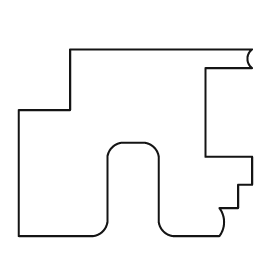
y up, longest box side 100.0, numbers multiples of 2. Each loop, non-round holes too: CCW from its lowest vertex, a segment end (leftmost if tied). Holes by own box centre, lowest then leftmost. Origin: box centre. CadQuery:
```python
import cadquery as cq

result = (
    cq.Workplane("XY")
    .moveTo(-50.0, -40.0)
    .lineTo(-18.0, -40.0)
    .threePointArc((-14.0, -38.0), (-12.0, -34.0))
    .lineTo(-12.0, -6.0)
    .threePointArc((-10.0, -2.0), (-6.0, 0.0))
    .lineTo(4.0, 0.0)
    .threePointArc((8.0, -2.0), (10.0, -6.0))
    .lineTo(10.0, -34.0)
    .threePointArc((12.0, -38.0), (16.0, -40.0))
    .lineTo(36.0, -40.0)
    .threePointArc((38.0, -34.0), (36.0, -28.0))
    .lineTo(44.0, -28.0)
    .lineTo(44.0, -18.0)
    .lineTo(50.0, -18.0)
    .lineTo(50.0, -6.0)
    .lineTo(30.0, -6.0)
    .lineTo(30.0, 32.0)
    .lineTo(50.0, 32.0)
    .threePointArc((48.0, 36.0), (50.0, 40.0))
    .lineTo(-28.0, 40.0)
    .lineTo(-28.0, 14.0)
    .lineTo(-50.0, 14.0)
    .close()
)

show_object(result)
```